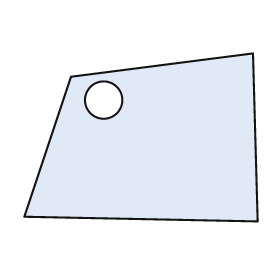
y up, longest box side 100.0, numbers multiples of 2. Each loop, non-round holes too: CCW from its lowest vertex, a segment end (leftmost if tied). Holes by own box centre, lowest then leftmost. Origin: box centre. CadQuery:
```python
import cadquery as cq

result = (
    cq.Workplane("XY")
    .moveTo(50.0, -36.0)
    .lineTo(48.0, 36.0)
    .lineTo(-30.0, 26.0)
    .lineTo(-50.0, -34.0)
    .close()
    .moveTo(-16.0, 16.0)
    .circle(8.0)
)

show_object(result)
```